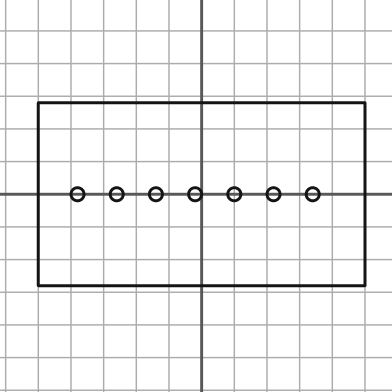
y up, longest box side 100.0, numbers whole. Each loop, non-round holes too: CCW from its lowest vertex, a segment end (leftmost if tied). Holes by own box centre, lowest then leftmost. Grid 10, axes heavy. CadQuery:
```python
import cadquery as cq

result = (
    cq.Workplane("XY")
    .moveTo(-50.0, -28.0)
    .lineTo(50.0, -28.0)
    .lineTo(50.0, 28.0)
    .lineTo(-50.0, 28.0)
    .close()
    .moveTo(-38.0, 0.0)
    .circle(2.0)
    .moveTo(-26.0, 0.0)
    .circle(2.0)
    .moveTo(-14.0, 0.0)
    .circle(2.0)
    .moveTo(-2.0, 0.0)
    .circle(2.0)
    .moveTo(10.0, 0.0)
    .circle(2.0)
    .moveTo(22.0, 0.0)
    .circle(2.0)
    .moveTo(34.0, 0.0)
    .circle(2.0)
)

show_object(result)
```